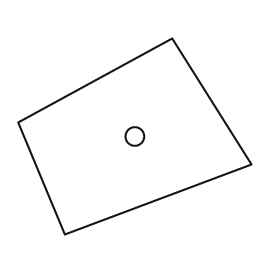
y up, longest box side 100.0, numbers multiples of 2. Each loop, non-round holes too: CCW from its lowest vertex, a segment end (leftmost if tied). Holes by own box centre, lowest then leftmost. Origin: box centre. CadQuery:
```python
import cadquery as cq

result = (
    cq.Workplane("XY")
    .moveTo(-30.0, -42.0)
    .lineTo(50.0, -12.0)
    .lineTo(16.0, 42.0)
    .lineTo(-50.0, 6.0)
    .close()
    .moveTo(0.0, 0.0)
    .circle(4.0)
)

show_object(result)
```